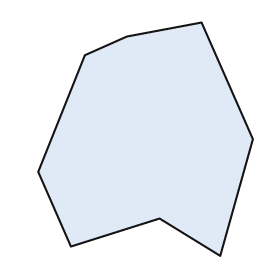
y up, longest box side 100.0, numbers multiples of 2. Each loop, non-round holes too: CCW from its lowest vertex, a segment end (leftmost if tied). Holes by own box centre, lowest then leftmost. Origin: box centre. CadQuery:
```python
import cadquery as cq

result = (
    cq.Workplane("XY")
    .moveTo(32.0, -50.0)
    .lineTo(46.0, 0.0)
    .lineTo(24.0, 50.0)
    .lineTo(-8.0, 44.0)
    .lineTo(-26.0, 36.0)
    .lineTo(-46.0, -14.0)
    .lineTo(-32.0, -46.0)
    .lineTo(6.0, -34.0)
    .close()
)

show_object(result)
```